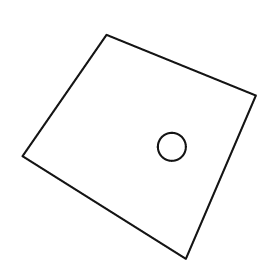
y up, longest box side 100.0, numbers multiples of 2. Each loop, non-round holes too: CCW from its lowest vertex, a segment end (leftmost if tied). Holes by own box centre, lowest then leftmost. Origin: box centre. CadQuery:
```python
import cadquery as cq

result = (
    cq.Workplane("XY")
    .moveTo(20.0, -48.0)
    .lineTo(50.0, 22.0)
    .lineTo(-14.0, 48.0)
    .lineTo(-50.0, -4.0)
    .close()
    .moveTo(14.0, 0.0)
    .circle(6.0)
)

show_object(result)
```